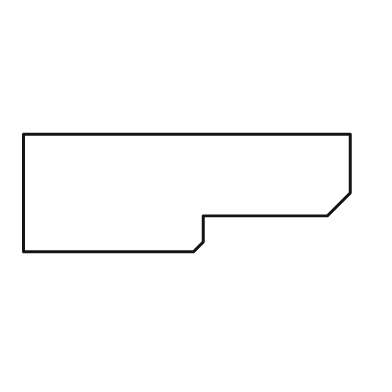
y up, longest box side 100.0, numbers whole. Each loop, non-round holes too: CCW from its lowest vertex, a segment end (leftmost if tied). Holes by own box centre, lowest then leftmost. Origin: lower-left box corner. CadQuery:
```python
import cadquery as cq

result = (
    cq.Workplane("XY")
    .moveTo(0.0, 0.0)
    .lineTo(52.0, 0.0)
    .lineTo(55.0, 3.0)
    .lineTo(55.0, 11.0)
    .lineTo(93.0, 11.0)
    .lineTo(100.0, 18.0)
    .lineTo(100.0, 36.0)
    .lineTo(0.0, 36.0)
    .close()
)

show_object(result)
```